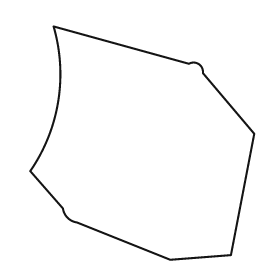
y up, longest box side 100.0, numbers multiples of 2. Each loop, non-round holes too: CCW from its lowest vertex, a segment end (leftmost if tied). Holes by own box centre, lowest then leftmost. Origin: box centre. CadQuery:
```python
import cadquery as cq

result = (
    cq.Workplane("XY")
    .moveTo(12.0, -50.0)
    .lineTo(38.0, -48.0)
    .lineTo(48.0, 4.0)
    .lineTo(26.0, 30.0)
    .threePointArc((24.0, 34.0), (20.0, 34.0))
    .lineTo(-38.0, 50.0)
    .threePointArc((-36.0, 18.0), (-48.0, -12.0))
    .lineTo(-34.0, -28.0)
    .threePointArc((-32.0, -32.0), (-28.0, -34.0))
    .close()
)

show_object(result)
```